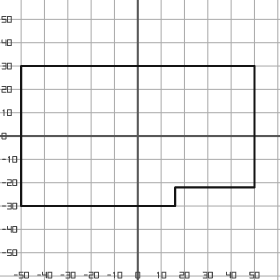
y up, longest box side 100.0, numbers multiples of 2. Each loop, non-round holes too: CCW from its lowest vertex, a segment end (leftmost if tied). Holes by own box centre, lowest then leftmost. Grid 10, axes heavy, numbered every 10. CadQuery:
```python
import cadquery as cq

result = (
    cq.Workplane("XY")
    .moveTo(-50.0, -30.0)
    .lineTo(16.0, -30.0)
    .lineTo(16.0, -22.0)
    .lineTo(50.0, -22.0)
    .lineTo(50.0, 30.0)
    .lineTo(-50.0, 30.0)
    .close()
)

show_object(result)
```